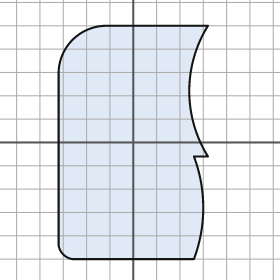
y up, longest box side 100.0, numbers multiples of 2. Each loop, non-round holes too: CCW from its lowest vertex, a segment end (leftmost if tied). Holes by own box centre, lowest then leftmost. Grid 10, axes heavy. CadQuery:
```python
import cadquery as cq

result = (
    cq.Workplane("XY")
    .moveTo(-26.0, -50.0)
    .lineTo(26.0, -50.0)
    .threePointArc((30.0, -28.0), (26.0, -6.0))
    .lineTo(32.0, -6.0)
    .threePointArc((24.0, 22.0), (32.0, 50.0))
    .lineTo(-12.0, 50.0)
    .threePointArc((-26.0, 44.0), (-32.0, 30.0))
    .lineTo(-32.0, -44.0)
    .threePointArc((-30.0, -48.0), (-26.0, -50.0))
    .close()
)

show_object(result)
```